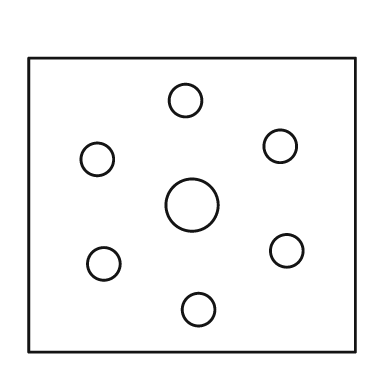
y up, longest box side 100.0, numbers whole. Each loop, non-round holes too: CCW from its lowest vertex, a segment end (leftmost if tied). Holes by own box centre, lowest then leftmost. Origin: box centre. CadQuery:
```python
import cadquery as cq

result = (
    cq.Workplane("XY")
    .moveTo(-50.0, -45.0)
    .lineTo(50.0, -45.0)
    .lineTo(50.0, 45.0)
    .lineTo(-50.0, 45.0)
    .close()
    .moveTo(2.0, -32.0)
    .circle(5.0)
    .moveTo(-27.0, -18.0)
    .circle(5.0)
    .moveTo(29.0, -14.0)
    .circle(5.0)
    .moveTo(0.0, 0.0)
    .circle(8.0)
    .moveTo(-29.0, 14.0)
    .circle(5.0)
    .moveTo(27.0, 18.0)
    .circle(5.0)
    .moveTo(-2.0, 32.0)
    .circle(5.0)
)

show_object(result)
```